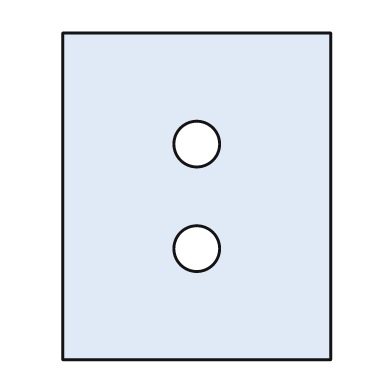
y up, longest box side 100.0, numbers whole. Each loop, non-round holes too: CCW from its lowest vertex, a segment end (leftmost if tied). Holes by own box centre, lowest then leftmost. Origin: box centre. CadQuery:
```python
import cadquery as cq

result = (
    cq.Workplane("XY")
    .moveTo(-41.0, -50.0)
    .lineTo(41.0, -50.0)
    .lineTo(41.0, 50.0)
    .lineTo(-41.0, 50.0)
    .close()
    .moveTo(0.0, -16.0)
    .circle(7.0)
    .moveTo(0.0, 16.0)
    .circle(7.0)
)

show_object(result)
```